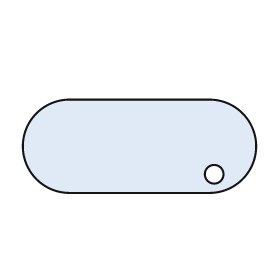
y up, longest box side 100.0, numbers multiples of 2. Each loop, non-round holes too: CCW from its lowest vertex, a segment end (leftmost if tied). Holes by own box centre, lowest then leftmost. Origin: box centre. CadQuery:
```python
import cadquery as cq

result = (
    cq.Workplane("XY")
    .moveTo(-30.0, -20.0)
    .lineTo(30.0, -20.0)
    .threePointArc((50.0, 0.0), (30.0, 20.0))
    .lineTo(-30.0, 20.0)
    .threePointArc((-50.0, 0.0), (-30.0, -20.0))
    .close()
    .moveTo(32.0, -12.0)
    .circle(4.0)
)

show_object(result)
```